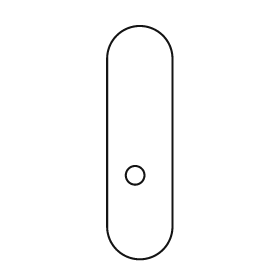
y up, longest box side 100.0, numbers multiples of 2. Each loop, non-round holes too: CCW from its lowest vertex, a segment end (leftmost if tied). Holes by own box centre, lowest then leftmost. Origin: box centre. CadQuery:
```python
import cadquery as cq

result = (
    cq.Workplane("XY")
    .moveTo(-14.0, -36.0)
    .threePointArc((0.0, -50.0), (14.0, -36.0))
    .lineTo(14.0, 36.0)
    .threePointArc((0.0, 50.0), (-14.0, 36.0))
    .close()
    .moveTo(-2.0, -14.0)
    .circle(4.0)
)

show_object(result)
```